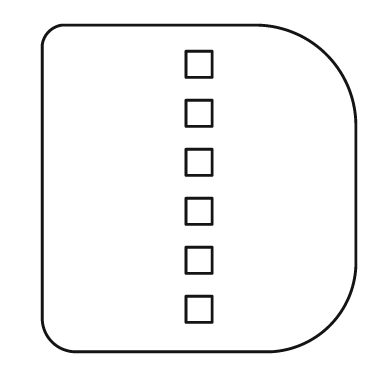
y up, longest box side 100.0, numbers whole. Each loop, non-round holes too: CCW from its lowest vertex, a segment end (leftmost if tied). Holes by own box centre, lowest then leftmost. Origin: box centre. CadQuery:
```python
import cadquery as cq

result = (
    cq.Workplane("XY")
    .moveTo(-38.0, -50.0)
    .lineTo(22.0, -50.0)
    .threePointArc((40.0, -42.0), (48.0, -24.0))
    .lineTo(48.0, 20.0)
    .threePointArc((39.0, 41.0), (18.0, 50.0))
    .lineTo(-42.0, 50.0)
    .threePointArc((-46.0, 48.0), (-48.0, 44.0))
    .lineTo(-48.0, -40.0)
    .threePointArc((-45.0, -47.0), (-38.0, -50.0))
    .close()
    .moveTo(-4.0, -41.0)
    .lineTo(4.0, -41.0)
    .lineTo(4.0, -33.0)
    .lineTo(-4.0, -33.0)
    .close()
    .moveTo(-4.0, -26.0)
    .lineTo(4.0, -26.0)
    .lineTo(4.0, -18.0)
    .lineTo(-4.0, -18.0)
    .close()
    .moveTo(-4.0, -11.0)
    .lineTo(4.0, -11.0)
    .lineTo(4.0, -3.0)
    .lineTo(-4.0, -3.0)
    .close()
    .moveTo(-4.0, 4.0)
    .lineTo(4.0, 4.0)
    .lineTo(4.0, 12.0)
    .lineTo(-4.0, 12.0)
    .close()
    .moveTo(-4.0, 19.0)
    .lineTo(4.0, 19.0)
    .lineTo(4.0, 27.0)
    .lineTo(-4.0, 27.0)
    .close()
    .moveTo(-4.0, 34.0)
    .lineTo(4.0, 34.0)
    .lineTo(4.0, 42.0)
    .lineTo(-4.0, 42.0)
    .close()
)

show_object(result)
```